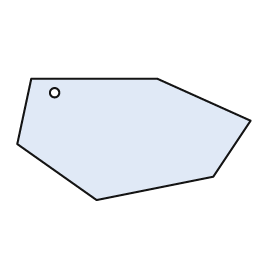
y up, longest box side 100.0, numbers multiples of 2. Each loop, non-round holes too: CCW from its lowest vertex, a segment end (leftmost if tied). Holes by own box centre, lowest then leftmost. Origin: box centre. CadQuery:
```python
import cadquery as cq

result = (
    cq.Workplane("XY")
    .moveTo(-16.0, -26.0)
    .lineTo(34.0, -16.0)
    .lineTo(50.0, 8.0)
    .lineTo(10.0, 26.0)
    .lineTo(-44.0, 26.0)
    .lineTo(-50.0, -2.0)
    .close()
    .moveTo(-34.0, 20.0)
    .circle(2.0)
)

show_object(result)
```